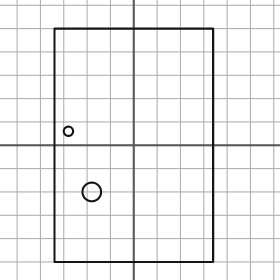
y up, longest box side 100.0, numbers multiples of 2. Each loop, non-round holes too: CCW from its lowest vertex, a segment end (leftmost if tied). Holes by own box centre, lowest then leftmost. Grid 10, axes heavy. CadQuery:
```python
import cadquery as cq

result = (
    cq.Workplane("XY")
    .moveTo(-34.0, -50.0)
    .lineTo(34.0, -50.0)
    .lineTo(34.0, 50.0)
    .lineTo(-34.0, 50.0)
    .close()
    .moveTo(-18.0, -20.0)
    .circle(4.0)
    .moveTo(-28.0, 6.0)
    .circle(2.0)
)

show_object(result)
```